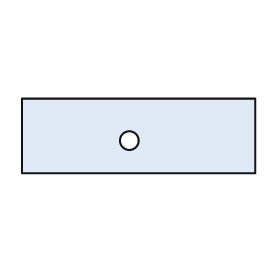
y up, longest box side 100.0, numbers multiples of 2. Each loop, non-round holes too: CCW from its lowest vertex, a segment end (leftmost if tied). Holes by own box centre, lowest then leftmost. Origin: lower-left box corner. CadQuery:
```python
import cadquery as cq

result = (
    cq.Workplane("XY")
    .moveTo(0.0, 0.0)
    .lineTo(100.0, 0.0)
    .lineTo(100.0, 32.0)
    .lineTo(0.0, 32.0)
    .close()
    .moveTo(46.0, 14.0)
    .circle(4.0)
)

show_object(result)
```